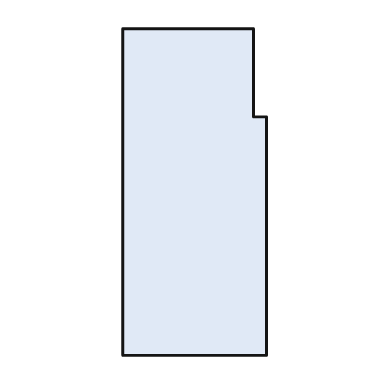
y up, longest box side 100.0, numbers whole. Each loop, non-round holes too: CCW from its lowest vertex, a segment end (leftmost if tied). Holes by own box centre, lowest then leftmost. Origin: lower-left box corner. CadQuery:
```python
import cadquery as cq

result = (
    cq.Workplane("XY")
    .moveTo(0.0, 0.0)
    .lineTo(44.0, 0.0)
    .lineTo(44.0, 73.0)
    .lineTo(40.0, 73.0)
    .lineTo(40.0, 100.0)
    .lineTo(0.0, 100.0)
    .close()
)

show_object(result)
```